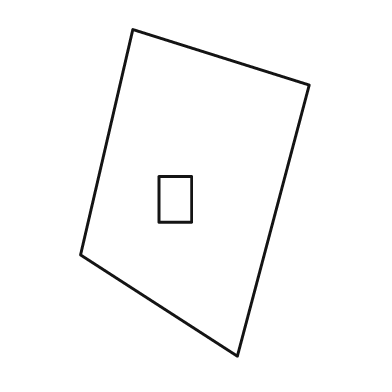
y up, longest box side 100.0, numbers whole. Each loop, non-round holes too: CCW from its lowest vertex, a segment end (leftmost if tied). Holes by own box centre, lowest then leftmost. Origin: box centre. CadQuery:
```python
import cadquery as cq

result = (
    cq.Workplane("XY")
    .moveTo(13.0, -50.0)
    .lineTo(35.0, 33.0)
    .lineTo(-19.0, 50.0)
    .lineTo(-35.0, -19.0)
    .close()
    .moveTo(-11.0, -9.0)
    .lineTo(-1.0, -9.0)
    .lineTo(-1.0, 5.0)
    .lineTo(-11.0, 5.0)
    .close()
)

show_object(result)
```